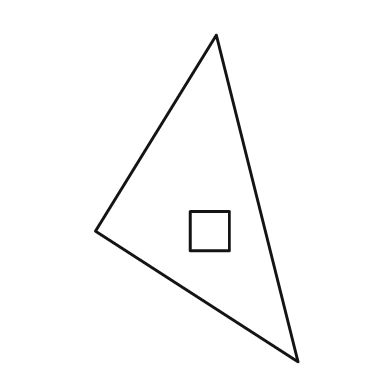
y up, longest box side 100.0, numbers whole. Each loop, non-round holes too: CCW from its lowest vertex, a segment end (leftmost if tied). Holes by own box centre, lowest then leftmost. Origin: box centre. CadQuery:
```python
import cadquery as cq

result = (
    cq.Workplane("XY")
    .moveTo(31.0, -50.0)
    .lineTo(6.0, 50.0)
    .lineTo(-31.0, -10.0)
    .close()
    .moveTo(-2.0, -16.0)
    .lineTo(10.0, -16.0)
    .lineTo(10.0, -4.0)
    .lineTo(-2.0, -4.0)
    .close()
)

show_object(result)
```